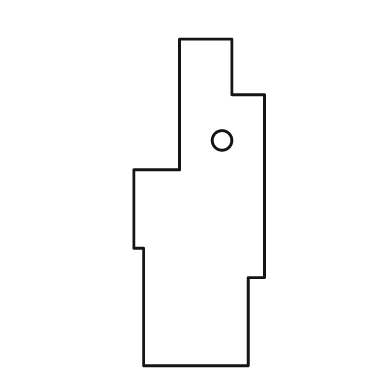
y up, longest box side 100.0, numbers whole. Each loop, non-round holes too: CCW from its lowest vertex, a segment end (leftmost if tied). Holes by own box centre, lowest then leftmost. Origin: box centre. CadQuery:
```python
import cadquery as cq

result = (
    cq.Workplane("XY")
    .moveTo(-17.0, -50.0)
    .lineTo(15.0, -50.0)
    .lineTo(15.0, -23.0)
    .lineTo(20.0, -23.0)
    .lineTo(20.0, 33.0)
    .lineTo(10.0, 33.0)
    .lineTo(10.0, 50.0)
    .lineTo(-6.0, 50.0)
    .lineTo(-6.0, 10.0)
    .lineTo(-20.0, 10.0)
    .lineTo(-20.0, -14.0)
    .lineTo(-17.0, -14.0)
    .close()
    .moveTo(7.0, 19.0)
    .circle(3.0)
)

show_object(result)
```